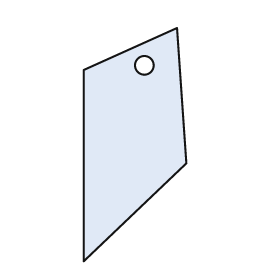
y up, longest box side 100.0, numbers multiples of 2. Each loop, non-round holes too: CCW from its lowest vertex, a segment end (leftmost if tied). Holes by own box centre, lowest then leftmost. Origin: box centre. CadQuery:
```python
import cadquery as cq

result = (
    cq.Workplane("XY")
    .moveTo(-22.0, -50.0)
    .lineTo(22.0, -8.0)
    .lineTo(18.0, 50.0)
    .lineTo(-22.0, 32.0)
    .close()
    .moveTo(4.0, 34.0)
    .circle(4.0)
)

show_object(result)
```